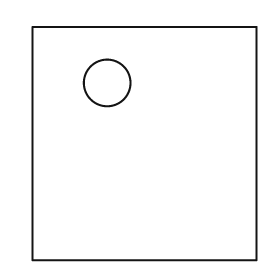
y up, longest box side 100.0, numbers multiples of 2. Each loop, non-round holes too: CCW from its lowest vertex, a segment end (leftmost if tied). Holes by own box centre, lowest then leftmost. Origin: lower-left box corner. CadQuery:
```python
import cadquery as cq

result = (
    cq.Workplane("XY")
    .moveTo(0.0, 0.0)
    .lineTo(96.0, 0.0)
    .lineTo(96.0, 100.0)
    .lineTo(0.0, 100.0)
    .close()
    .moveTo(32.0, 76.0)
    .circle(10.0)
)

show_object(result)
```